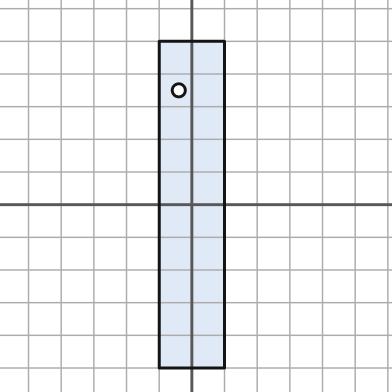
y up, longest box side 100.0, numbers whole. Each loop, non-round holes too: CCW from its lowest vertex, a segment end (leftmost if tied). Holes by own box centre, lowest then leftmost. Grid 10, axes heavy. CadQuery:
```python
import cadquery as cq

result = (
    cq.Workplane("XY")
    .moveTo(-10.0, -50.0)
    .lineTo(10.0, -50.0)
    .lineTo(10.0, 50.0)
    .lineTo(-10.0, 50.0)
    .close()
    .moveTo(-4.0, 35.0)
    .circle(2.0)
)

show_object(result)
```